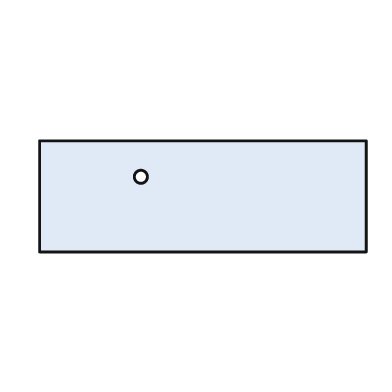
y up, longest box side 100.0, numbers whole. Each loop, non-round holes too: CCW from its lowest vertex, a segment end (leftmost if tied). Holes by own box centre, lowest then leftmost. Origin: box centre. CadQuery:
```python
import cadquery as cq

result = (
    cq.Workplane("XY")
    .moveTo(-50.0, -17.0)
    .lineTo(50.0, -17.0)
    .lineTo(50.0, 17.0)
    .lineTo(-50.0, 17.0)
    .close()
    .moveTo(-19.0, 6.0)
    .circle(2.0)
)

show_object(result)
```